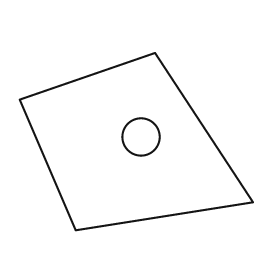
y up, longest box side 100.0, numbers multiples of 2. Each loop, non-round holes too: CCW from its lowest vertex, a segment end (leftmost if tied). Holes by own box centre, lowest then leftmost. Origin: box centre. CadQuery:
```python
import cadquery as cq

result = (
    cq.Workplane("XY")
    .moveTo(-26.0, -38.0)
    .lineTo(50.0, -26.0)
    .lineTo(8.0, 38.0)
    .lineTo(-50.0, 18.0)
    .close()
    .moveTo(2.0, 2.0)
    .circle(8.0)
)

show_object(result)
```